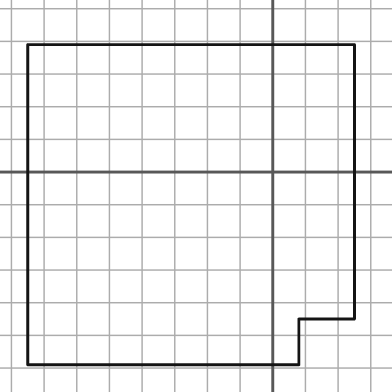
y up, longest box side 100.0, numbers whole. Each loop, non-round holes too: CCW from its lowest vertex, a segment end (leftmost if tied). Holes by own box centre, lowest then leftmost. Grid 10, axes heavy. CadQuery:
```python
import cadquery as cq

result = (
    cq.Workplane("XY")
    .moveTo(-75.0, -59.0)
    .lineTo(8.0, -59.0)
    .lineTo(8.0, -45.0)
    .lineTo(25.0, -45.0)
    .lineTo(25.0, 39.0)
    .lineTo(-75.0, 39.0)
    .close()
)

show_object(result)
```